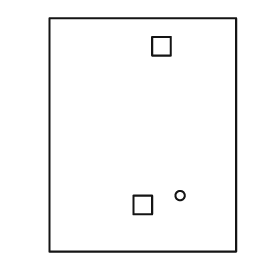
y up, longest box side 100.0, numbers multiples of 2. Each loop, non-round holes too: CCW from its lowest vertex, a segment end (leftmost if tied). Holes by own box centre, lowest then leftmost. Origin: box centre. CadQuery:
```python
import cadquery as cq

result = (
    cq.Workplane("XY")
    .moveTo(-40.0, -50.0)
    .lineTo(40.0, -50.0)
    .lineTo(40.0, 50.0)
    .lineTo(-40.0, 50.0)
    .close()
    .moveTo(-4.0, -34.0)
    .lineTo(4.0, -34.0)
    .lineTo(4.0, -26.0)
    .lineTo(-4.0, -26.0)
    .close()
    .moveTo(16.0, -26.0)
    .circle(2.0)
    .moveTo(4.0, 34.0)
    .lineTo(12.0, 34.0)
    .lineTo(12.0, 42.0)
    .lineTo(4.0, 42.0)
    .close()
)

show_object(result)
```